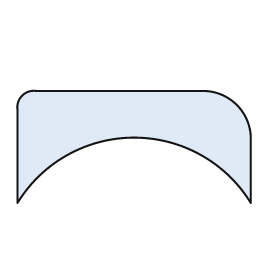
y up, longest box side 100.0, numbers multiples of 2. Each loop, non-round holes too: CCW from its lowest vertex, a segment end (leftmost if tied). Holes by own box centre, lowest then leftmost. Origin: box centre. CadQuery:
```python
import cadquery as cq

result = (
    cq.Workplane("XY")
    .moveTo(-50.0, -24.0)
    .threePointArc((0.0, 4.0), (50.0, -24.0))
    .lineTo(50.0, 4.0)
    .threePointArc((44.0, 18.0), (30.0, 24.0))
    .lineTo(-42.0, 24.0)
    .threePointArc((-48.0, 22.0), (-50.0, 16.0))
    .close()
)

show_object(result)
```